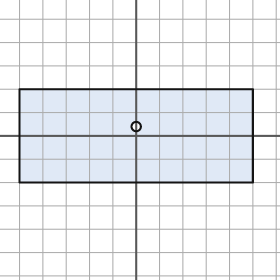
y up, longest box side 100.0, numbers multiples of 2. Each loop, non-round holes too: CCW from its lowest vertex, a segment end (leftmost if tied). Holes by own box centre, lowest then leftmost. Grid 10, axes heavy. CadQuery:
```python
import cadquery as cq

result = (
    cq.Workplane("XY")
    .moveTo(-50.0, -20.0)
    .lineTo(50.0, -20.0)
    .lineTo(50.0, 20.0)
    .lineTo(-50.0, 20.0)
    .close()
    .moveTo(0.0, 4.0)
    .circle(2.0)
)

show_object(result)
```